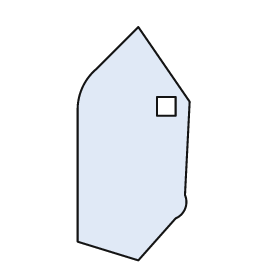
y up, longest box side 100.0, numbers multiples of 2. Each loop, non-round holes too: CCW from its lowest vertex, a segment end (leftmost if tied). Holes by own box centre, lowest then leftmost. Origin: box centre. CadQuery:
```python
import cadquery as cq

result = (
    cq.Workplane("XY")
    .moveTo(2.0, -50.0)
    .lineTo(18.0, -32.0)
    .threePointArc((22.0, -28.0), (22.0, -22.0))
    .lineTo(24.0, 18.0)
    .lineTo(2.0, 50.0)
    .lineTo(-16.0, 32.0)
    .threePointArc((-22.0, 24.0), (-24.0, 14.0))
    .lineTo(-24.0, -42.0)
    .close()
    .moveTo(10.0, 12.0)
    .lineTo(18.0, 12.0)
    .lineTo(18.0, 20.0)
    .lineTo(10.0, 20.0)
    .close()
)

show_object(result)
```